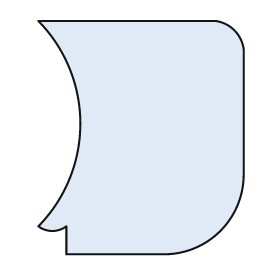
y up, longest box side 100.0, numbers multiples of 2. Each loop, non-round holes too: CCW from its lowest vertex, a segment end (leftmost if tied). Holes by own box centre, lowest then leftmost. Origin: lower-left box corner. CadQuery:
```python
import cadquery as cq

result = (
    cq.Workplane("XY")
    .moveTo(12.0, 0.0)
    .lineTo(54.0, 0.0)
    .threePointArc((78.0, 10.0), (88.0, 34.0))
    .lineTo(88.0, 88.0)
    .threePointArc((84.0, 96.0), (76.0, 100.0))
    .lineTo(0.0, 100.0)
    .threePointArc((18.0, 56.0), (0.0, 12.0))
    .threePointArc((6.0, 10.0), (12.0, 12.0))
    .close()
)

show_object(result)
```